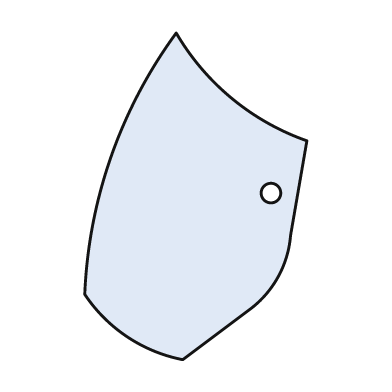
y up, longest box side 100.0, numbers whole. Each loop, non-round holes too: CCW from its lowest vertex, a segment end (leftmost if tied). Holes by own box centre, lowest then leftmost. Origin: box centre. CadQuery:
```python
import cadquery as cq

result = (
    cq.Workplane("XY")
    .moveTo(-4.0, -50.0)
    .lineTo(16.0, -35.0)
    .threePointArc((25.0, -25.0), (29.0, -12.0))
    .lineTo(34.0, 17.0)
    .threePointArc((11.0, 30.0), (-6.0, 50.0))
    .threePointArc((-26.0, 12.0), (-34.0, -30.0))
    .threePointArc((-21.0, -43.0), (-4.0, -50.0))
    .close()
    .moveTo(23.0, 1.0)
    .circle(3.0)
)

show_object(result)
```